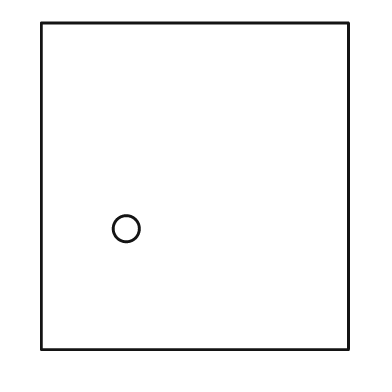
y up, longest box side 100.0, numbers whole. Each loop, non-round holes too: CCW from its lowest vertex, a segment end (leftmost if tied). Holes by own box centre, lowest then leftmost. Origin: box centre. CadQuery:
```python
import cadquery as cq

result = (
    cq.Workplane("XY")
    .moveTo(-47.0, -50.0)
    .lineTo(47.0, -50.0)
    .lineTo(47.0, 50.0)
    .lineTo(-47.0, 50.0)
    .close()
    .moveTo(-21.0, -13.0)
    .circle(4.0)
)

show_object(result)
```